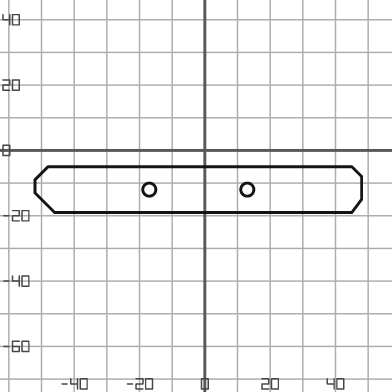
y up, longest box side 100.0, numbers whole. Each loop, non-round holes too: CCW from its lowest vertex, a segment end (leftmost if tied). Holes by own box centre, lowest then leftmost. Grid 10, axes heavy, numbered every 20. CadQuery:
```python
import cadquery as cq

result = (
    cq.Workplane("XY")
    .moveTo(-46.0, -19.0)
    .lineTo(45.0, -19.0)
    .lineTo(48.0, -15.0)
    .lineTo(48.0, -8.0)
    .lineTo(45.0, -5.0)
    .lineTo(-48.0, -5.0)
    .lineTo(-52.0, -9.0)
    .lineTo(-52.0, -13.0)
    .close()
    .moveTo(-17.0, -12.0)
    .circle(2.0)
    .moveTo(13.0, -12.0)
    .circle(2.0)
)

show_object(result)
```